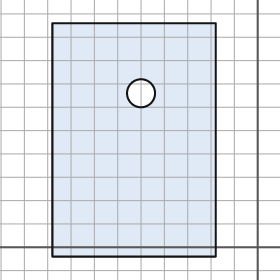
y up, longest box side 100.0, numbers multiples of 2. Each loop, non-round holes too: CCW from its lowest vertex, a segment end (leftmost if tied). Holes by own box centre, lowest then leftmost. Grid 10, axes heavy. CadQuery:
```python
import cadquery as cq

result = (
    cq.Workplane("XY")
    .moveTo(-88.0, -4.0)
    .lineTo(-18.0, -4.0)
    .lineTo(-18.0, 96.0)
    .lineTo(-88.0, 96.0)
    .close()
    .moveTo(-50.0, 66.0)
    .circle(6.0)
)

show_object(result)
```